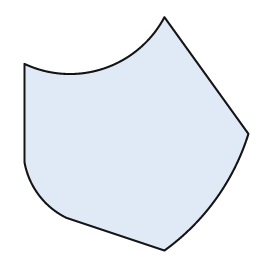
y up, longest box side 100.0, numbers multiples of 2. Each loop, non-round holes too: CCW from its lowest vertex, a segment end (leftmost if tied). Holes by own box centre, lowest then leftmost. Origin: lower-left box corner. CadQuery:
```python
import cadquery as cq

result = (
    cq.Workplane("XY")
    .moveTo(60.0, 0.0)
    .threePointArc((82.0, 22.0), (96.0, 50.0))
    .lineTo(60.0, 100.0)
    .threePointArc((34.0, 78.0), (0.0, 80.0))
    .lineTo(0.0, 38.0)
    .threePointArc((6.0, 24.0), (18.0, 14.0))
    .close()
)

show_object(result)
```